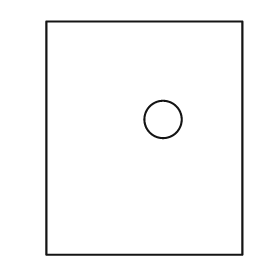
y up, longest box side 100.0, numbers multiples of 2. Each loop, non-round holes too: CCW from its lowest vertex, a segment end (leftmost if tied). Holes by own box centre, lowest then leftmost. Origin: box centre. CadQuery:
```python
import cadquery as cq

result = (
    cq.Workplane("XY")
    .moveTo(-42.0, -50.0)
    .lineTo(42.0, -50.0)
    .lineTo(42.0, 50.0)
    .lineTo(-42.0, 50.0)
    .close()
    .moveTo(8.0, 8.0)
    .circle(8.0)
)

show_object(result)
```